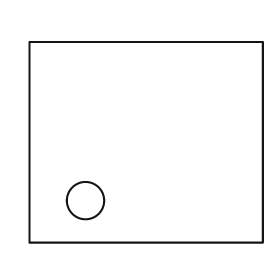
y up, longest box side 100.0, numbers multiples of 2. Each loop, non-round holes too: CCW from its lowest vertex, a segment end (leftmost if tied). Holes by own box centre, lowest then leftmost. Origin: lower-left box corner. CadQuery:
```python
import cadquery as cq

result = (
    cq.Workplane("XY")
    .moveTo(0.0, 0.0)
    .lineTo(100.0, 0.0)
    .lineTo(100.0, 86.0)
    .lineTo(0.0, 86.0)
    .close()
    .moveTo(24.0, 18.0)
    .circle(8.0)
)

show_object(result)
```